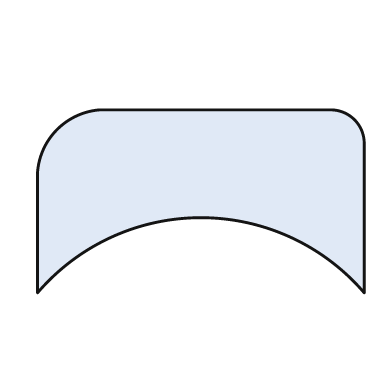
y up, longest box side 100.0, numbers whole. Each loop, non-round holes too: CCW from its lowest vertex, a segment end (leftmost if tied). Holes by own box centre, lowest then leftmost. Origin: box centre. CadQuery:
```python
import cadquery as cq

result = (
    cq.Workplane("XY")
    .moveTo(-50.0, -28.0)
    .threePointArc((0.0, -5.0), (50.0, -28.0))
    .lineTo(50.0, 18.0)
    .threePointArc((47.0, 25.0), (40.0, 28.0))
    .lineTo(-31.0, 28.0)
    .threePointArc((-44.0, 22.0), (-50.0, 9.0))
    .close()
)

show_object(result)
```